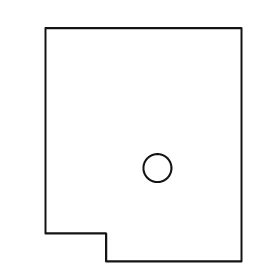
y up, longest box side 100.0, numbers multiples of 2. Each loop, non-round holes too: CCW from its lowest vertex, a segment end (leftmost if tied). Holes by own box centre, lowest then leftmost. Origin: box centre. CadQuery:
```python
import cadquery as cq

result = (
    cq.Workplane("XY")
    .moveTo(-16.0, -50.0)
    .lineTo(42.0, -50.0)
    .lineTo(42.0, 50.0)
    .lineTo(-42.0, 50.0)
    .lineTo(-42.0, -38.0)
    .lineTo(-16.0, -38.0)
    .close()
    .moveTo(6.0, -10.0)
    .circle(6.0)
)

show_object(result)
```